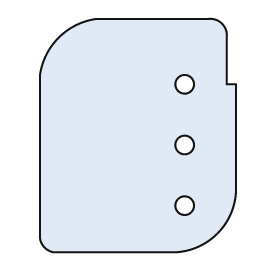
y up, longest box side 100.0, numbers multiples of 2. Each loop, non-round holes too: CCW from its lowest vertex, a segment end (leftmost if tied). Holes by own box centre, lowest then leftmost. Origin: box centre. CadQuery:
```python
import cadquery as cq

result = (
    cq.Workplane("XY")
    .moveTo(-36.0, -50.0)
    .lineTo(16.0, -50.0)
    .threePointArc((34.0, -42.0), (42.0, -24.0))
    .lineTo(42.0, 22.0)
    .lineTo(38.0, 22.0)
    .lineTo(38.0, 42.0)
    .threePointArc((36.0, 48.0), (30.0, 50.0))
    .lineTo(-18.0, 50.0)
    .threePointArc((-34.0, 42.0), (-42.0, 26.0))
    .lineTo(-42.0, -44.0)
    .threePointArc((-40.0, -48.0), (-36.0, -50.0))
    .close()
    .moveTo(20.0, -30.0)
    .circle(4.0)
    .moveTo(20.0, -4.0)
    .circle(4.0)
    .moveTo(20.0, 22.0)
    .circle(4.0)
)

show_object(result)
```